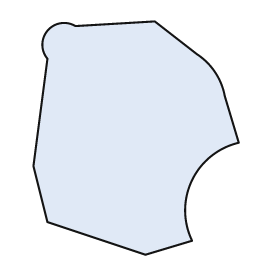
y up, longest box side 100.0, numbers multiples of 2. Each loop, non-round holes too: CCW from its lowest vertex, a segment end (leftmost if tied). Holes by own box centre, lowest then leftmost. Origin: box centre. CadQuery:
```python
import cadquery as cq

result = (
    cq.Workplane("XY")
    .moveTo(4.0, -50.0)
    .lineTo(24.0, -44.0)
    .threePointArc((24.0, -18.0), (44.0, -2.0))
    .lineTo(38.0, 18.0)
    .threePointArc((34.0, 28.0), (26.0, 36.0))
    .lineTo(8.0, 50.0)
    .lineTo(-26.0, 48.0)
    .threePointArc((-38.0, 46.0), (-38.0, 34.0))
    .lineTo(-44.0, -12.0)
    .lineTo(-38.0, -36.0)
    .close()
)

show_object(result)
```